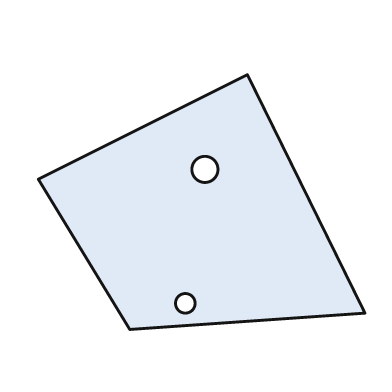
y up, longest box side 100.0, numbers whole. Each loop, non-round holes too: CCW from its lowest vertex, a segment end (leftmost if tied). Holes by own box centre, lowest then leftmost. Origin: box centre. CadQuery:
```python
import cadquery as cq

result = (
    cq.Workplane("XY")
    .moveTo(-22.0, -39.0)
    .lineTo(50.0, -34.0)
    .lineTo(14.0, 39.0)
    .lineTo(-50.0, 7.0)
    .close()
    .moveTo(-5.0, -31.0)
    .circle(3.0)
    .moveTo(1.0, 10.0)
    .circle(4.0)
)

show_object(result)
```